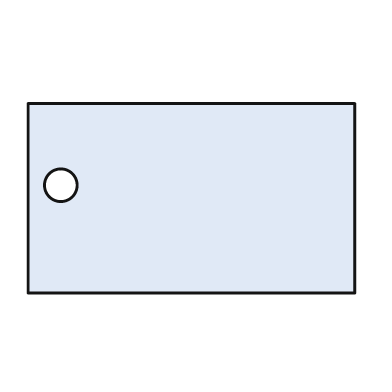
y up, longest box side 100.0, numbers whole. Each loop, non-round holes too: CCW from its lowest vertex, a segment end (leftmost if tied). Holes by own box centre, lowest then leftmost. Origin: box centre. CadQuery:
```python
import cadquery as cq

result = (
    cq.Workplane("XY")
    .moveTo(-50.0, -29.0)
    .lineTo(50.0, -29.0)
    .lineTo(50.0, 29.0)
    .lineTo(-50.0, 29.0)
    .close()
    .moveTo(-40.0, 4.0)
    .circle(5.0)
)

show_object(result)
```